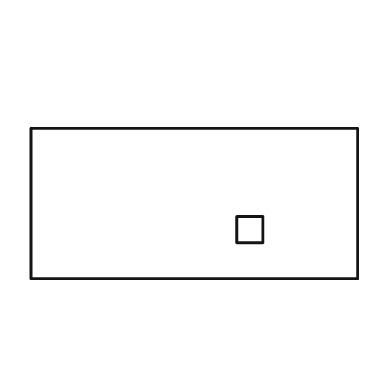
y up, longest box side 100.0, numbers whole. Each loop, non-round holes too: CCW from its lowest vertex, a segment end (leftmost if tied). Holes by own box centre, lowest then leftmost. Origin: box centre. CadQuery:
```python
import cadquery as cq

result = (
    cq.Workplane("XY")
    .moveTo(-50.0, -23.0)
    .lineTo(50.0, -23.0)
    .lineTo(50.0, 23.0)
    .lineTo(-50.0, 23.0)
    .close()
    .moveTo(13.0, -12.0)
    .lineTo(21.0, -12.0)
    .lineTo(21.0, -4.0)
    .lineTo(13.0, -4.0)
    .close()
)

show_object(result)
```